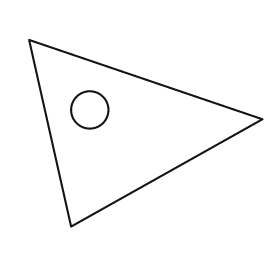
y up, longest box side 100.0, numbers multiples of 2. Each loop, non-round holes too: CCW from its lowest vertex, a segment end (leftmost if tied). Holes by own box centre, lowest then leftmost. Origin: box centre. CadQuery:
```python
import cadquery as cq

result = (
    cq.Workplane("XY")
    .moveTo(-32.0, -40.0)
    .lineTo(50.0, 6.0)
    .lineTo(-50.0, 40.0)
    .close()
    .moveTo(-24.0, 10.0)
    .circle(8.0)
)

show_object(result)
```